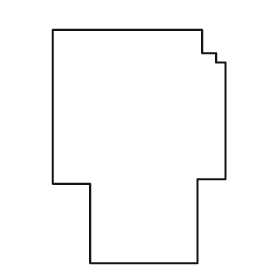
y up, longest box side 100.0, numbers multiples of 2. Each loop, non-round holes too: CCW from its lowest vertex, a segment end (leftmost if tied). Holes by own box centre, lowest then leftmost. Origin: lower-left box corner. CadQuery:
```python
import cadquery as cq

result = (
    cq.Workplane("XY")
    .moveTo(16.0, 0.0)
    .lineTo(62.0, 0.0)
    .lineTo(62.0, 36.0)
    .lineTo(74.0, 36.0)
    .lineTo(74.0, 86.0)
    .lineTo(70.0, 86.0)
    .lineTo(70.0, 90.0)
    .lineTo(64.0, 90.0)
    .lineTo(64.0, 100.0)
    .lineTo(0.0, 100.0)
    .lineTo(0.0, 34.0)
    .lineTo(16.0, 34.0)
    .close()
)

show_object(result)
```